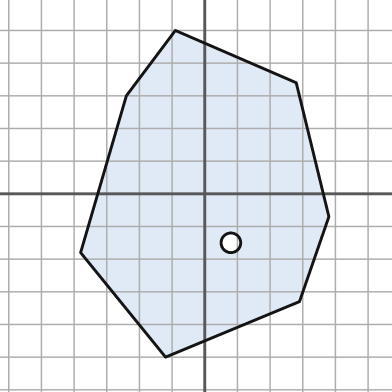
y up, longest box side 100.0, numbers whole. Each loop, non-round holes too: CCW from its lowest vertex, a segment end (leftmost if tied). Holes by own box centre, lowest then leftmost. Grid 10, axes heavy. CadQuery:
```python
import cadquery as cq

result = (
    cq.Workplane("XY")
    .moveTo(-12.0, -50.0)
    .lineTo(29.0, -33.0)
    .lineTo(38.0, -7.0)
    .lineTo(28.0, 34.0)
    .lineTo(-9.0, 50.0)
    .lineTo(-24.0, 30.0)
    .lineTo(-38.0, -18.0)
    .close()
    .moveTo(8.0, -15.0)
    .circle(3.0)
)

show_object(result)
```